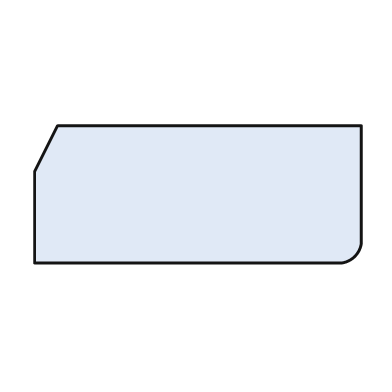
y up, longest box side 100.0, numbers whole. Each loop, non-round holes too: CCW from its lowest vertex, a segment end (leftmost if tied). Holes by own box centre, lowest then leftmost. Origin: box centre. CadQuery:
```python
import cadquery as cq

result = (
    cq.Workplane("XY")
    .moveTo(-50.0, -21.0)
    .lineTo(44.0, -21.0)
    .threePointArc((48.0, -19.0), (50.0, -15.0))
    .lineTo(50.0, 21.0)
    .lineTo(-43.0, 21.0)
    .lineTo(-50.0, 7.0)
    .close()
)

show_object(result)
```